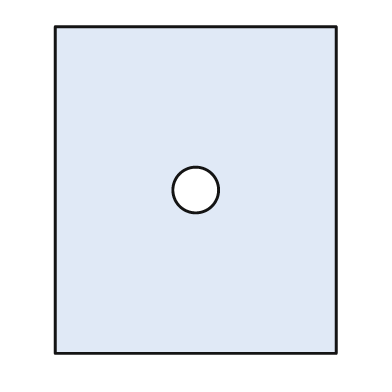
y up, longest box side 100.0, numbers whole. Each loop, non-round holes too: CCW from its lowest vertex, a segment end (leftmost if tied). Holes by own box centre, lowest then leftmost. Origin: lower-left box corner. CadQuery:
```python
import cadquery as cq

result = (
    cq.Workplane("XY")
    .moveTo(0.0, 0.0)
    .lineTo(86.0, 0.0)
    .lineTo(86.0, 100.0)
    .lineTo(0.0, 100.0)
    .close()
    .moveTo(43.0, 50.0)
    .circle(7.0)
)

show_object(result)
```